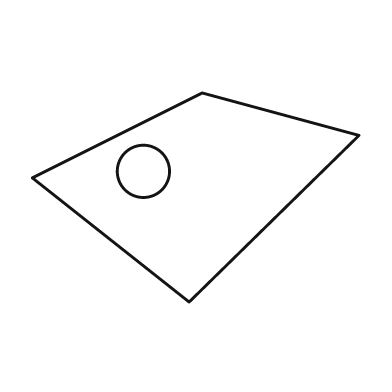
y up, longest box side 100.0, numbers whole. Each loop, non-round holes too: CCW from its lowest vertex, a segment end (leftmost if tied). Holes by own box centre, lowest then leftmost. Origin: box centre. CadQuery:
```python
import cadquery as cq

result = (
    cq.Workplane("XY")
    .moveTo(-2.0, -32.0)
    .lineTo(50.0, 19.0)
    .lineTo(2.0, 32.0)
    .lineTo(-50.0, 6.0)
    .close()
    .moveTo(-16.0, 8.0)
    .circle(8.0)
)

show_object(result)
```